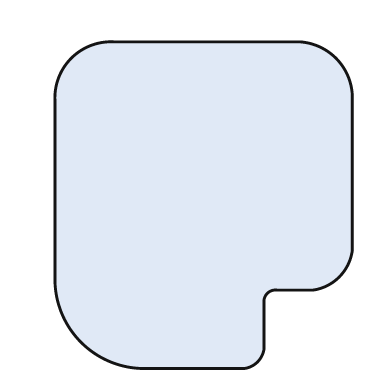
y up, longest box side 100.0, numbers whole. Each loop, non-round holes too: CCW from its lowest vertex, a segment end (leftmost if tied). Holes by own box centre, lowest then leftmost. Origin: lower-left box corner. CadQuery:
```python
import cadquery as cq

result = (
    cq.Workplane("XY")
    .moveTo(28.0, 0.0)
    .lineTo(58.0, 0.0)
    .threePointArc((62.0, 2.0), (64.0, 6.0))
    .lineTo(64.0, 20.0)
    .threePointArc((65.0, 23.0), (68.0, 24.0))
    .lineTo(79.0, 24.0)
    .threePointArc((87.0, 28.0), (91.0, 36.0))
    .lineTo(91.0, 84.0)
    .threePointArc((86.0, 95.0), (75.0, 100.0))
    .lineTo(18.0, 100.0)
    .threePointArc((5.0, 95.0), (0.0, 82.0))
    .lineTo(0.0, 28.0)
    .threePointArc((8.0, 8.0), (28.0, 0.0))
    .close()
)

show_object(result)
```